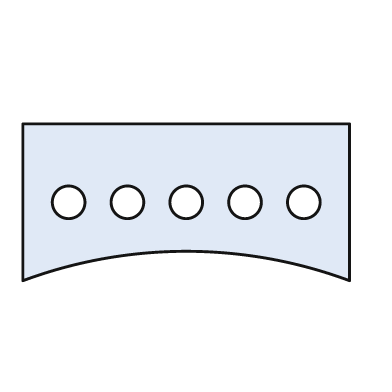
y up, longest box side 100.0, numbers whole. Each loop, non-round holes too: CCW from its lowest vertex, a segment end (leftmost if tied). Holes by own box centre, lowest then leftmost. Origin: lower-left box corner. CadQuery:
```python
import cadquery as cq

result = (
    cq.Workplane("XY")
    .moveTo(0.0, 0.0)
    .threePointArc((50.0, 9.0), (100.0, 0.0))
    .lineTo(100.0, 48.0)
    .lineTo(0.0, 48.0)
    .close()
    .moveTo(14.0, 24.0)
    .circle(5.0)
    .moveTo(32.0, 24.0)
    .circle(5.0)
    .moveTo(50.0, 24.0)
    .circle(5.0)
    .moveTo(68.0, 24.0)
    .circle(5.0)
    .moveTo(86.0, 24.0)
    .circle(5.0)
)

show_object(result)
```